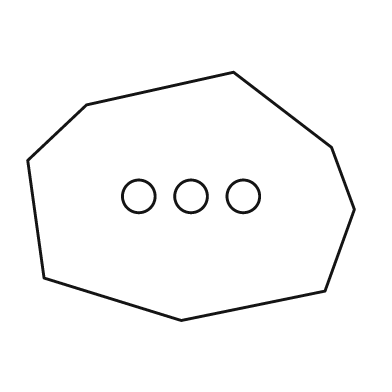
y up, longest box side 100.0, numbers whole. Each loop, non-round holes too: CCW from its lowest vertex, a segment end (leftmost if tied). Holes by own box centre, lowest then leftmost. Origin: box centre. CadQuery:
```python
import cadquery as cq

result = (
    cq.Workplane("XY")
    .moveTo(-3.0, -38.0)
    .lineTo(41.0, -29.0)
    .lineTo(50.0, -4.0)
    .lineTo(43.0, 15.0)
    .lineTo(13.0, 38.0)
    .lineTo(-32.0, 28.0)
    .lineTo(-50.0, 11.0)
    .lineTo(-45.0, -25.0)
    .close()
    .moveTo(-16.0, 0.0)
    .circle(5.0)
    .moveTo(0.0, 0.0)
    .circle(5.0)
    .moveTo(16.0, 0.0)
    .circle(5.0)
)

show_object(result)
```